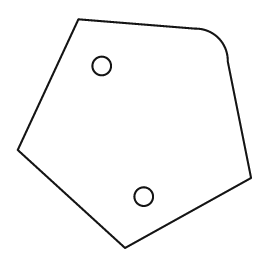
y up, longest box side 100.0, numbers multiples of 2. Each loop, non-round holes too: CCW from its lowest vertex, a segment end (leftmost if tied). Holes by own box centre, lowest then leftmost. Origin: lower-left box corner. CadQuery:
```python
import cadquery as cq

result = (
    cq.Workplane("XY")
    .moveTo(46.0, 0.0)
    .lineTo(100.0, 30.0)
    .lineTo(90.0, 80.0)
    .threePointArc((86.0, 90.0), (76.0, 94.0))
    .lineTo(26.0, 98.0)
    .lineTo(0.0, 42.0)
    .close()
    .moveTo(54.0, 22.0)
    .circle(4.0)
    .moveTo(36.0, 78.0)
    .circle(4.0)
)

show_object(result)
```